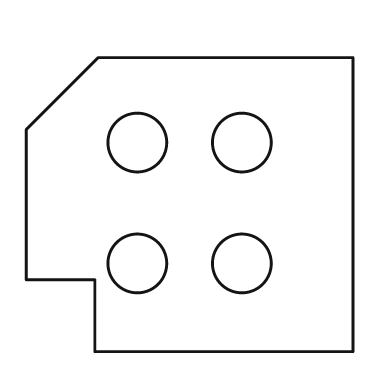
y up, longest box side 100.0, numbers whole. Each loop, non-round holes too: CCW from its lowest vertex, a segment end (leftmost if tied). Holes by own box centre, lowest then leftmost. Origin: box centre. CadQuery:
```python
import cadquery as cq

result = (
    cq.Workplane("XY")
    .moveTo(-29.0, -45.0)
    .lineTo(50.0, -45.0)
    .lineTo(50.0, 45.0)
    .lineTo(-28.0, 45.0)
    .lineTo(-50.0, 23.0)
    .lineTo(-50.0, -23.0)
    .lineTo(-29.0, -23.0)
    .close()
    .moveTo(-16.0, -18.0)
    .circle(9.0)
    .moveTo(16.0, -18.0)
    .circle(9.0)
    .moveTo(-16.0, 19.0)
    .circle(9.0)
    .moveTo(16.0, 19.0)
    .circle(9.0)
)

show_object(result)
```